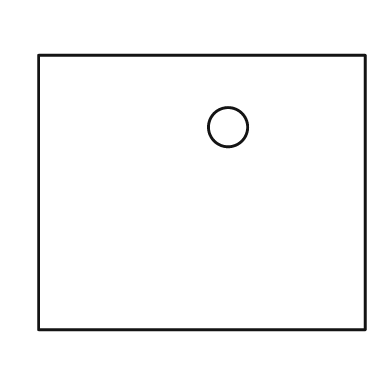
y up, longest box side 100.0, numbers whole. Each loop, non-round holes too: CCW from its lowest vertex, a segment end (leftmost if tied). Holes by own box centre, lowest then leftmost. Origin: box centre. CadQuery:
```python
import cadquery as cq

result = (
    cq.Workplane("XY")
    .moveTo(-50.0, -42.0)
    .lineTo(50.0, -42.0)
    .lineTo(50.0, 42.0)
    .lineTo(-50.0, 42.0)
    .close()
    .moveTo(8.0, 20.0)
    .circle(6.0)
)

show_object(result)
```